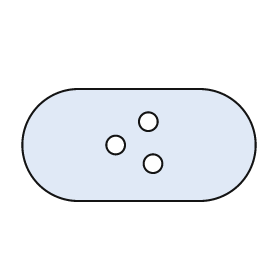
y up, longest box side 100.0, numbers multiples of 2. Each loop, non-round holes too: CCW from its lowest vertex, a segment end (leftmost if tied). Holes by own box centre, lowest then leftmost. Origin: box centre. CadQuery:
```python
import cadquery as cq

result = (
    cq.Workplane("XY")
    .moveTo(-26.0, -24.0)
    .lineTo(26.0, -24.0)
    .threePointArc((50.0, 0.0), (26.0, 24.0))
    .lineTo(-26.0, 24.0)
    .threePointArc((-50.0, 0.0), (-26.0, -24.0))
    .close()
    .moveTo(6.0, -8.0)
    .circle(4.0)
    .moveTo(-10.0, 0.0)
    .circle(4.0)
    .moveTo(4.0, 10.0)
    .circle(4.0)
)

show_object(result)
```